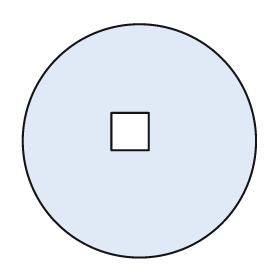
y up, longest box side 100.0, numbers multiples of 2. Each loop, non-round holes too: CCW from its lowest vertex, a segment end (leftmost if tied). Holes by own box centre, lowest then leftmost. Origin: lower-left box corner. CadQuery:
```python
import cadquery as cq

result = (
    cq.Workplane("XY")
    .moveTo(50.0, 50.0)
    .circle(50.0)
    .moveTo(38.0, 46.0)
    .lineTo(54.0, 46.0)
    .lineTo(54.0, 62.0)
    .lineTo(38.0, 62.0)
    .close()
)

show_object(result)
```